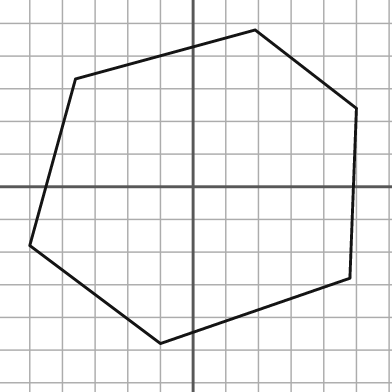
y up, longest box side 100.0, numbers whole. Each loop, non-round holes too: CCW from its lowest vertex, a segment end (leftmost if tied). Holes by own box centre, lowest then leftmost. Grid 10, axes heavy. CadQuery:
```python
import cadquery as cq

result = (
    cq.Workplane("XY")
    .moveTo(-10.0, -48.0)
    .lineTo(48.0, -28.0)
    .lineTo(50.0, 24.0)
    .lineTo(19.0, 48.0)
    .lineTo(-36.0, 33.0)
    .lineTo(-50.0, -18.0)
    .close()
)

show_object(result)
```